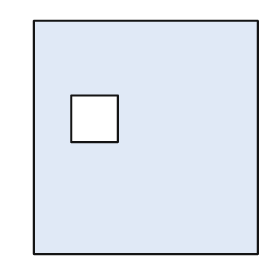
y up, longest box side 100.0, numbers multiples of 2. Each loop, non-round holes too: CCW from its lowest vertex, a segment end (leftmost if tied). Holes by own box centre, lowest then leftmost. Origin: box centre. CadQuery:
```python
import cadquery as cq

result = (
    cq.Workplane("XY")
    .moveTo(-48.0, -50.0)
    .lineTo(48.0, -50.0)
    .lineTo(48.0, 50.0)
    .lineTo(-48.0, 50.0)
    .close()
    .moveTo(-32.0, -2.0)
    .lineTo(-12.0, -2.0)
    .lineTo(-12.0, 18.0)
    .lineTo(-32.0, 18.0)
    .close()
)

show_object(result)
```